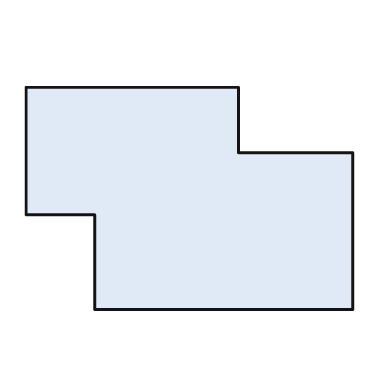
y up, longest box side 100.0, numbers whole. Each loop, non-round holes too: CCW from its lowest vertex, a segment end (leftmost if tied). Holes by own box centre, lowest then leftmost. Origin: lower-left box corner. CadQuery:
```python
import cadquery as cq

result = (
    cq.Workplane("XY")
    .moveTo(21.0, 0.0)
    .lineTo(100.0, 0.0)
    .lineTo(100.0, 48.0)
    .lineTo(65.0, 48.0)
    .lineTo(65.0, 68.0)
    .lineTo(0.0, 68.0)
    .lineTo(0.0, 29.0)
    .lineTo(21.0, 29.0)
    .close()
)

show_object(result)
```